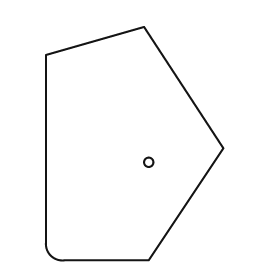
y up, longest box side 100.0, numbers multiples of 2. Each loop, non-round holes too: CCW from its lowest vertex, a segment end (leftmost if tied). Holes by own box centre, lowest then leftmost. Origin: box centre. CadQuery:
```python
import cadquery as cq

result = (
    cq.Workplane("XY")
    .moveTo(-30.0, -50.0)
    .lineTo(6.0, -50.0)
    .lineTo(38.0, -2.0)
    .lineTo(4.0, 50.0)
    .lineTo(-38.0, 38.0)
    .lineTo(-38.0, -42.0)
    .threePointArc((-36.0, -48.0), (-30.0, -50.0))
    .close()
    .moveTo(6.0, -8.0)
    .circle(2.0)
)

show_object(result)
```